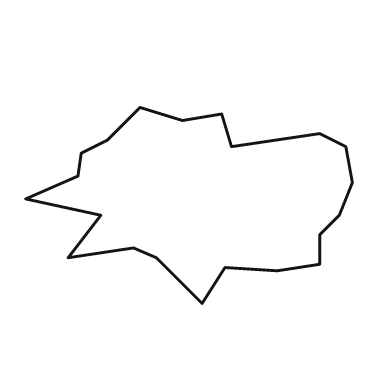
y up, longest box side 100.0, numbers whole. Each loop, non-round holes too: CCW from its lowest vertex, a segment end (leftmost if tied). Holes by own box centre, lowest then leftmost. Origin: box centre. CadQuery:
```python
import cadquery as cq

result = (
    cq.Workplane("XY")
    .moveTo(4.0, -30.0)
    .lineTo(11.0, -19.0)
    .lineTo(27.0, -20.0)
    .lineTo(40.0, -18.0)
    .lineTo(40.0, -9.0)
    .lineTo(46.0, -3.0)
    .lineTo(50.0, 7.0)
    .lineTo(48.0, 18.0)
    .lineTo(40.0, 22.0)
    .lineTo(13.0, 18.0)
    .lineTo(10.0, 28.0)
    .lineTo(-2.0, 26.0)
    .lineTo(-15.0, 30.0)
    .lineTo(-25.0, 20.0)
    .lineTo(-33.0, 16.0)
    .lineTo(-34.0, 9.0)
    .lineTo(-50.0, 2.0)
    .lineTo(-27.0, -3.0)
    .lineTo(-37.0, -16.0)
    .lineTo(-17.0, -13.0)
    .lineTo(-10.0, -16.0)
    .close()
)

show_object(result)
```